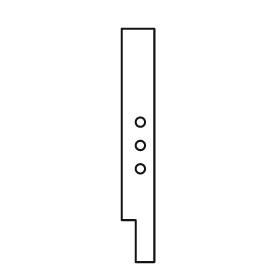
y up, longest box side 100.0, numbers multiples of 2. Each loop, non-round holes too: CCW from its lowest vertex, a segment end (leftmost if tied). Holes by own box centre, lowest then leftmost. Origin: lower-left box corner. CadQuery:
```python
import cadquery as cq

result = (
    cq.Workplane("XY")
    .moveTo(6.0, 0.0)
    .lineTo(14.0, 0.0)
    .lineTo(14.0, 100.0)
    .lineTo(0.0, 100.0)
    .lineTo(0.0, 18.0)
    .lineTo(6.0, 18.0)
    .close()
    .moveTo(8.0, 40.0)
    .circle(2.0)
    .moveTo(8.0, 50.0)
    .circle(2.0)
    .moveTo(8.0, 60.0)
    .circle(2.0)
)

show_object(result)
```